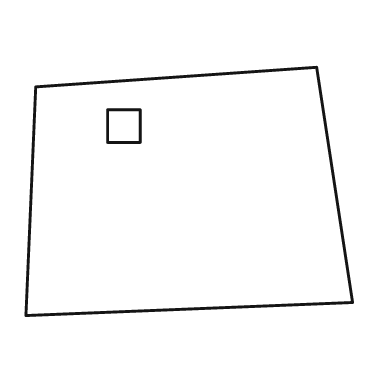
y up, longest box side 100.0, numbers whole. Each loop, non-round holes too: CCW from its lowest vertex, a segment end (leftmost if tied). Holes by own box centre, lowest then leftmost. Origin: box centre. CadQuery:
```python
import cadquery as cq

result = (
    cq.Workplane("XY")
    .moveTo(-50.0, -38.0)
    .lineTo(50.0, -34.0)
    .lineTo(39.0, 38.0)
    .lineTo(-47.0, 32.0)
    .close()
    .moveTo(-25.0, 15.0)
    .lineTo(-15.0, 15.0)
    .lineTo(-15.0, 25.0)
    .lineTo(-25.0, 25.0)
    .close()
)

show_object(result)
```